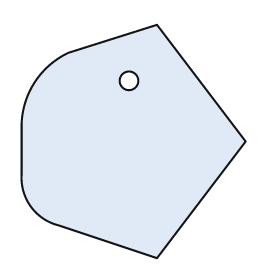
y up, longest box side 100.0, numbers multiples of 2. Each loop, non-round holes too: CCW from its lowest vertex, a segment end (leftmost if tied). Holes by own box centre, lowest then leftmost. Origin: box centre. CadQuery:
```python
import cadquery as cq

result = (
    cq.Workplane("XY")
    .moveTo(10.0, -50.0)
    .lineTo(48.0, 0.0)
    .lineTo(10.0, 50.0)
    .lineTo(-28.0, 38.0)
    .threePointArc((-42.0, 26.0), (-48.0, 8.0))
    .lineTo(-48.0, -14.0)
    .threePointArc((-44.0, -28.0), (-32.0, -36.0))
    .close()
    .moveTo(-2.0, 26.0)
    .circle(4.0)
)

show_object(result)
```